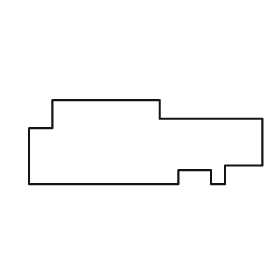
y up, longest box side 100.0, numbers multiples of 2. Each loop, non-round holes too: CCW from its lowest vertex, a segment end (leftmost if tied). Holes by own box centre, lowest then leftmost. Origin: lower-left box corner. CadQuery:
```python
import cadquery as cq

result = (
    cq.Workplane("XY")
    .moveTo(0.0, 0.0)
    .lineTo(64.0, 0.0)
    .lineTo(64.0, 6.0)
    .lineTo(78.0, 6.0)
    .lineTo(78.0, 0.0)
    .lineTo(84.0, 0.0)
    .lineTo(84.0, 8.0)
    .lineTo(100.0, 8.0)
    .lineTo(100.0, 28.0)
    .lineTo(56.0, 28.0)
    .lineTo(56.0, 36.0)
    .lineTo(10.0, 36.0)
    .lineTo(10.0, 24.0)
    .lineTo(0.0, 24.0)
    .close()
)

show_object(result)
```